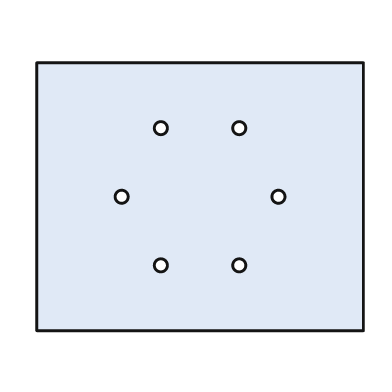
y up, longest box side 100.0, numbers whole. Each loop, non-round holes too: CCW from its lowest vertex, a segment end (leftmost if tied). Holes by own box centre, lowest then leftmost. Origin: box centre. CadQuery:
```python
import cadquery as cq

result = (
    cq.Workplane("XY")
    .moveTo(-50.0, -41.0)
    .lineTo(50.0, -41.0)
    .lineTo(50.0, 41.0)
    .lineTo(-50.0, 41.0)
    .close()
    .moveTo(-12.0, -21.0)
    .circle(2.0)
    .moveTo(12.0, -21.0)
    .circle(2.0)
    .moveTo(-24.0, 0.0)
    .circle(2.0)
    .moveTo(24.0, 0.0)
    .circle(2.0)
    .moveTo(-12.0, 21.0)
    .circle(2.0)
    .moveTo(12.0, 21.0)
    .circle(2.0)
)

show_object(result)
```